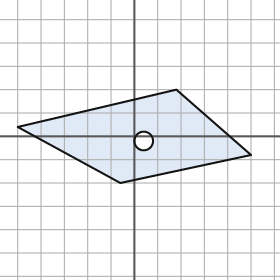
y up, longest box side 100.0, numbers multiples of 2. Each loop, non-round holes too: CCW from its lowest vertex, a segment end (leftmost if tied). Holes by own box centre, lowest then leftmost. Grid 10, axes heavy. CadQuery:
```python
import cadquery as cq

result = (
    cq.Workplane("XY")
    .moveTo(-6.0, -20.0)
    .lineTo(50.0, -8.0)
    .lineTo(18.0, 20.0)
    .lineTo(-50.0, 4.0)
    .close()
    .moveTo(4.0, -2.0)
    .circle(4.0)
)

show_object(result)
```